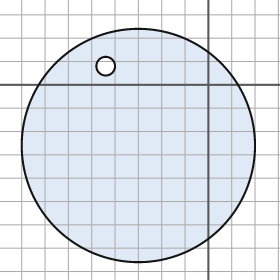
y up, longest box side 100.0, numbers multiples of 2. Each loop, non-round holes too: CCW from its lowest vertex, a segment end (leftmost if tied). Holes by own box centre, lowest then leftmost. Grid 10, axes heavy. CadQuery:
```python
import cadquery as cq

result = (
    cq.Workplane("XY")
    .moveTo(-30.0, -26.0)
    .circle(50.0)
    .moveTo(-44.0, 8.0)
    .circle(4.0)
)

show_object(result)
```